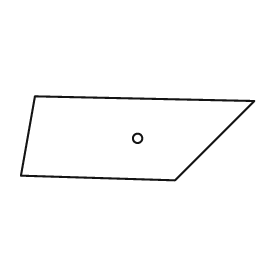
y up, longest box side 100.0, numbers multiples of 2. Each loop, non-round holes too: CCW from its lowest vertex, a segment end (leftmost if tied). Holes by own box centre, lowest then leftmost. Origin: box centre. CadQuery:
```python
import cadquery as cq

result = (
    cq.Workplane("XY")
    .moveTo(16.0, -18.0)
    .lineTo(50.0, 16.0)
    .lineTo(-44.0, 18.0)
    .lineTo(-50.0, -16.0)
    .close()
    .moveTo(0.0, 0.0)
    .circle(2.0)
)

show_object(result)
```